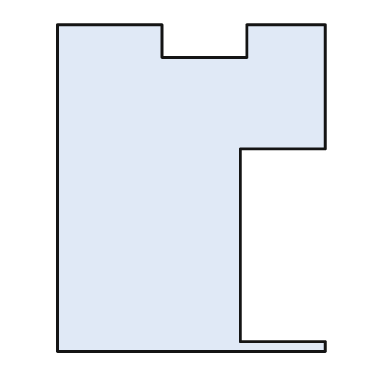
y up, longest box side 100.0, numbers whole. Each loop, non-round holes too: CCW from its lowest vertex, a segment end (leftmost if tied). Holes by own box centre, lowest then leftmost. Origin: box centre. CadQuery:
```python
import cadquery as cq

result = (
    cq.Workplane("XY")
    .moveTo(-41.0, -50.0)
    .lineTo(41.0, -50.0)
    .lineTo(41.0, -47.0)
    .lineTo(15.0, -47.0)
    .lineTo(15.0, 12.0)
    .lineTo(41.0, 12.0)
    .lineTo(41.0, 50.0)
    .lineTo(17.0, 50.0)
    .lineTo(17.0, 40.0)
    .lineTo(-9.0, 40.0)
    .lineTo(-9.0, 50.0)
    .lineTo(-41.0, 50.0)
    .close()
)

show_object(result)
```